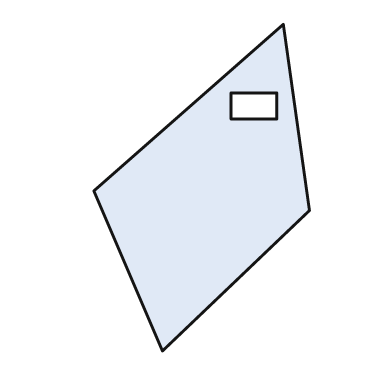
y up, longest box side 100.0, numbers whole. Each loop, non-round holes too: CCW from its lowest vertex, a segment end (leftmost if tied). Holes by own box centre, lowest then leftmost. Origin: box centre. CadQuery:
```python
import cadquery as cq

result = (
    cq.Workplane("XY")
    .moveTo(-12.0, -50.0)
    .lineTo(33.0, -7.0)
    .lineTo(25.0, 50.0)
    .lineTo(-33.0, -1.0)
    .close()
    .moveTo(9.0, 21.0)
    .lineTo(23.0, 21.0)
    .lineTo(23.0, 29.0)
    .lineTo(9.0, 29.0)
    .close()
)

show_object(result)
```